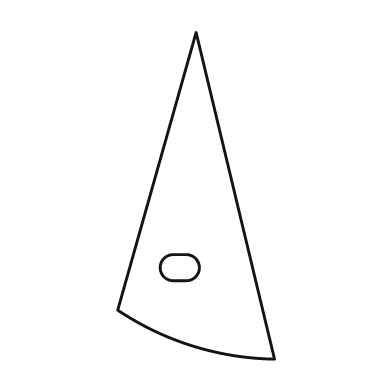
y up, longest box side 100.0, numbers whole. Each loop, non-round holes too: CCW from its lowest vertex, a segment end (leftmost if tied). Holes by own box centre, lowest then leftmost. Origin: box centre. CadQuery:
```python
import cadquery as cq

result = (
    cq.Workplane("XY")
    .moveTo(24.0, -50.0)
    .lineTo(0.0, 50.0)
    .lineTo(-24.0, -35.0)
    .threePointArc((-1.0, -46.0), (24.0, -50.0))
    .close()
    .moveTo(-7.0, -26.0)
    .lineTo(-3.0, -26.0)
    .threePointArc((1.0, -22.0), (-3.0, -18.0))
    .lineTo(-7.0, -18.0)
    .threePointArc((-11.0, -22.0), (-7.0, -26.0))
    .close()
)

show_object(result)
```